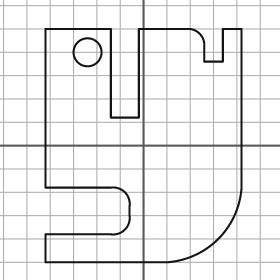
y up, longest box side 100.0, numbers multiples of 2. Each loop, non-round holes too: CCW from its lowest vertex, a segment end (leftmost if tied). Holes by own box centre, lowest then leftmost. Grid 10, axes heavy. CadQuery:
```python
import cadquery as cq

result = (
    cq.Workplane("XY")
    .moveTo(-42.0, -50.0)
    .lineTo(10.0, -50.0)
    .threePointArc((32.0, -40.0), (42.0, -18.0))
    .lineTo(42.0, 50.0)
    .lineTo(34.0, 50.0)
    .lineTo(34.0, 36.0)
    .lineTo(26.0, 36.0)
    .lineTo(26.0, 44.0)
    .threePointArc((24.0, 48.0), (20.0, 50.0))
    .lineTo(-2.0, 50.0)
    .lineTo(-2.0, 12.0)
    .lineTo(-14.0, 12.0)
    .lineTo(-14.0, 50.0)
    .lineTo(-42.0, 50.0)
    .lineTo(-42.0, -18.0)
    .lineTo(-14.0, -18.0)
    .threePointArc((-8.0, -20.0), (-6.0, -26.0))
    .lineTo(-6.0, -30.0)
    .threePointArc((-8.0, -36.0), (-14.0, -38.0))
    .lineTo(-42.0, -38.0)
    .close()
    .moveTo(-24.0, 40.0)
    .circle(6.0)
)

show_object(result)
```